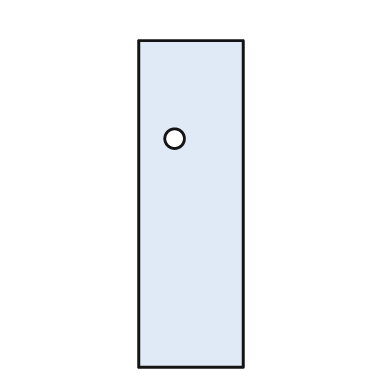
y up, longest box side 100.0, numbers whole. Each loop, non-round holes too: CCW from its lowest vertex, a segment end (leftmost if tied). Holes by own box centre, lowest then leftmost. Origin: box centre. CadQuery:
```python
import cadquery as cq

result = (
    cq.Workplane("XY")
    .moveTo(-16.0, -50.0)
    .lineTo(16.0, -50.0)
    .lineTo(16.0, 50.0)
    .lineTo(-16.0, 50.0)
    .close()
    .moveTo(-5.0, 20.0)
    .circle(3.0)
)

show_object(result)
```